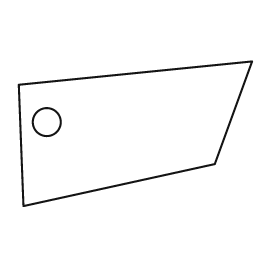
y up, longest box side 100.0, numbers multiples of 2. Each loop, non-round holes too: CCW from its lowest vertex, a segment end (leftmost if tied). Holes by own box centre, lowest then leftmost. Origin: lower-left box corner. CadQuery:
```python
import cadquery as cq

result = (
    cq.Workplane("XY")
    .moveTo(2.0, 0.0)
    .lineTo(84.0, 18.0)
    .lineTo(100.0, 62.0)
    .lineTo(0.0, 52.0)
    .close()
    .moveTo(12.0, 36.0)
    .circle(6.0)
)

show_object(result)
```